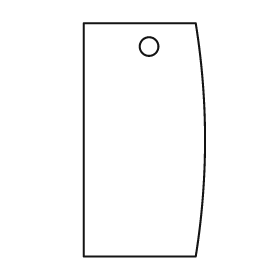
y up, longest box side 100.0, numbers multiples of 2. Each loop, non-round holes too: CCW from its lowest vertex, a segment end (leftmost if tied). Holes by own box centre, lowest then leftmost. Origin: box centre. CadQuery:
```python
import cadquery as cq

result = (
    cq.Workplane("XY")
    .moveTo(-26.0, -50.0)
    .lineTo(22.0, -50.0)
    .threePointArc((26.0, 0.0), (22.0, 50.0))
    .lineTo(-26.0, 50.0)
    .close()
    .moveTo(2.0, 40.0)
    .circle(4.0)
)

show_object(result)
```